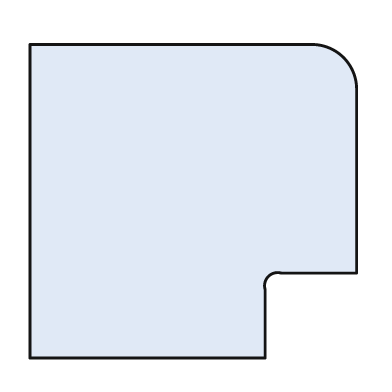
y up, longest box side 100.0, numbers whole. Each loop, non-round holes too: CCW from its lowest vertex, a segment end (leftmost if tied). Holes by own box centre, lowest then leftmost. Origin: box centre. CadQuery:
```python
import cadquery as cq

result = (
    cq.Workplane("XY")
    .moveTo(-50.0, -48.0)
    .lineTo(22.0, -48.0)
    .lineTo(22.0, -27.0)
    .threePointArc((23.0, -23.0), (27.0, -22.0))
    .lineTo(50.0, -22.0)
    .lineTo(50.0, 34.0)
    .threePointArc((46.0, 44.0), (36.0, 48.0))
    .lineTo(-50.0, 48.0)
    .close()
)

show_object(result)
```